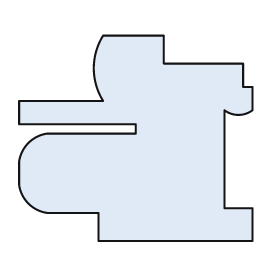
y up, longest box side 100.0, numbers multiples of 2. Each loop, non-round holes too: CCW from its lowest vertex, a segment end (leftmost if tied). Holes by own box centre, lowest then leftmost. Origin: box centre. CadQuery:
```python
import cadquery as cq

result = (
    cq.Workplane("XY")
    .moveTo(-16.0, -44.0)
    .lineTo(50.0, -44.0)
    .lineTo(50.0, -30.0)
    .lineTo(38.0, -30.0)
    .lineTo(38.0, 12.0)
    .threePointArc((44.0, 10.0), (50.0, 12.0))
    .lineTo(50.0, 22.0)
    .lineTo(46.0, 22.0)
    .lineTo(46.0, 32.0)
    .lineTo(12.0, 32.0)
    .lineTo(12.0, 44.0)
    .lineTo(-14.0, 44.0)
    .threePointArc((-18.0, 30.0), (-14.0, 16.0))
    .lineTo(-50.0, 16.0)
    .lineTo(-50.0, 6.0)
    .lineTo(0.0, 6.0)
    .lineTo(0.0, 2.0)
    .lineTo(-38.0, 2.0)
    .threePointArc((-46.0, -2.0), (-50.0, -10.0))
    .lineTo(-50.0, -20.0)
    .threePointArc((-46.0, -28.0), (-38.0, -32.0))
    .lineTo(-16.0, -32.0)
    .close()
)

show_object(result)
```